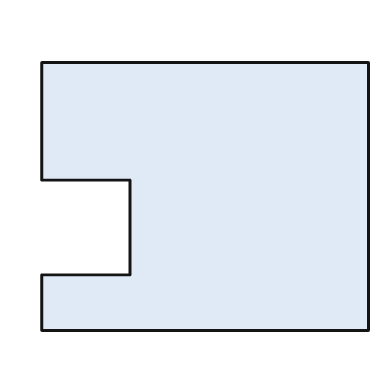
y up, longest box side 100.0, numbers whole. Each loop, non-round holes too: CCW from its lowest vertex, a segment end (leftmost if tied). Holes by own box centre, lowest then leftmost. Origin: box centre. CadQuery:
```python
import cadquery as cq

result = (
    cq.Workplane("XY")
    .moveTo(-50.0, -41.0)
    .lineTo(50.0, -41.0)
    .lineTo(50.0, 41.0)
    .lineTo(-50.0, 41.0)
    .lineTo(-50.0, 5.0)
    .lineTo(-23.0, 5.0)
    .lineTo(-23.0, -24.0)
    .lineTo(-50.0, -24.0)
    .close()
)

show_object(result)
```